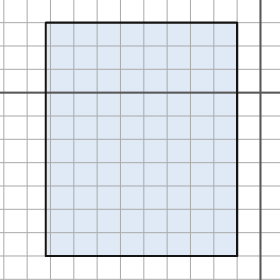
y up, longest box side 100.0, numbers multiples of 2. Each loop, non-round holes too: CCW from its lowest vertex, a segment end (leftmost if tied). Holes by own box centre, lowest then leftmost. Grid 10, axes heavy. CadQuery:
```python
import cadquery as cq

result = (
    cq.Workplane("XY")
    .moveTo(-92.0, -70.0)
    .lineTo(-10.0, -70.0)
    .lineTo(-10.0, 30.0)
    .lineTo(-92.0, 30.0)
    .close()
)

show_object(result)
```